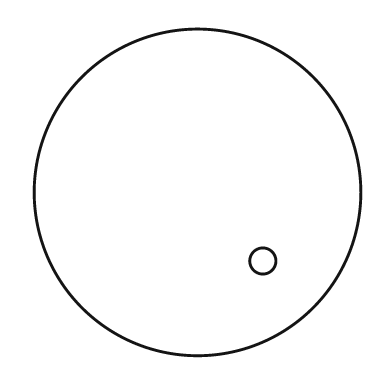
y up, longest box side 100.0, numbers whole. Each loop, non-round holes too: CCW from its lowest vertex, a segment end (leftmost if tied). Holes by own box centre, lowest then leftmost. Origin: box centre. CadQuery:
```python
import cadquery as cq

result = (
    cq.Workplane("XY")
    .moveTo(0.0, 0.0)
    .circle(50.0)
    .moveTo(20.0, -21.0)
    .circle(4.0)
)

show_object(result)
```